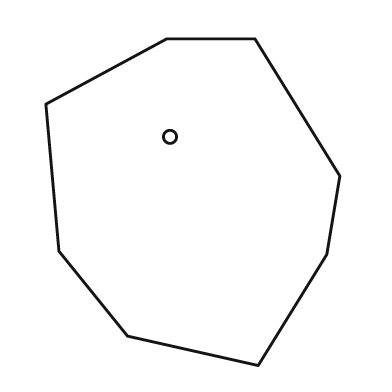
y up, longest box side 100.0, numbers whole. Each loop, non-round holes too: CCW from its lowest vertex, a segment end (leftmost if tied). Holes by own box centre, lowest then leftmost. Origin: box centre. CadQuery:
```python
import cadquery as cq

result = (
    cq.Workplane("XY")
    .moveTo(20.0, -50.0)
    .lineTo(41.0, -16.0)
    .lineTo(45.0, 8.0)
    .lineTo(19.0, 50.0)
    .lineTo(-8.0, 50.0)
    .lineTo(-45.0, 30.0)
    .lineTo(-41.0, -15.0)
    .lineTo(-20.0, -41.0)
    .close()
    .moveTo(-7.0, 20.0)
    .circle(2.0)
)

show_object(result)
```